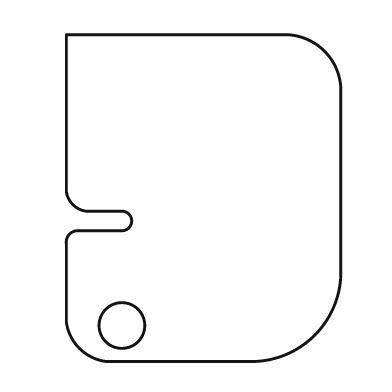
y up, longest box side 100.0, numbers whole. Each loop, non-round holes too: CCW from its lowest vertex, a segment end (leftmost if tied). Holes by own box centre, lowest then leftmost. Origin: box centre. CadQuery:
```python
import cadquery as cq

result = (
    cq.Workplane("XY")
    .moveTo(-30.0, -50.0)
    .lineTo(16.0, -50.0)
    .threePointArc((34.0, -42.0), (42.0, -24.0))
    .lineTo(42.0, 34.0)
    .threePointArc((37.0, 45.0), (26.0, 50.0))
    .lineTo(-42.0, 50.0)
    .lineTo(-42.0, 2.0)
    .threePointArc((-40.0, -2.0), (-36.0, -4.0))
    .lineTo(-25.0, -4.0)
    .threePointArc((-22.0, -7.0), (-25.0, -10.0))
    .lineTo(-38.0, -10.0)
    .threePointArc((-41.0, -11.0), (-42.0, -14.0))
    .lineTo(-42.0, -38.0)
    .threePointArc((-38.0, -46.0), (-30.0, -50.0))
    .close()
    .moveTo(-25.0, -39.0)
    .circle(7.0)
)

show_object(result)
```